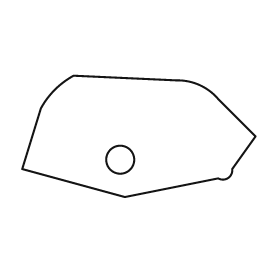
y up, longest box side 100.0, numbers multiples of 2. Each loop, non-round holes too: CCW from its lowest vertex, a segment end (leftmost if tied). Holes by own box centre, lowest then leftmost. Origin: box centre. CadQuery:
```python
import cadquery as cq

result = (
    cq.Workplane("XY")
    .moveTo(-6.0, -26.0)
    .lineTo(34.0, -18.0)
    .threePointArc((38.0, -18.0), (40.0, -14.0))
    .lineTo(50.0, 0.0)
    .lineTo(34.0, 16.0)
    .threePointArc((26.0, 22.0), (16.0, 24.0))
    .lineTo(-28.0, 26.0)
    .threePointArc((-36.0, 20.0), (-42.0, 12.0))
    .lineTo(-50.0, -14.0)
    .close()
    .moveTo(-8.0, -10.0)
    .circle(6.0)
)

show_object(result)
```